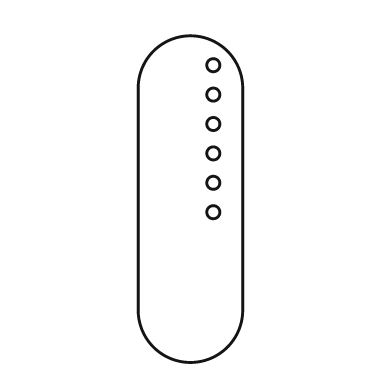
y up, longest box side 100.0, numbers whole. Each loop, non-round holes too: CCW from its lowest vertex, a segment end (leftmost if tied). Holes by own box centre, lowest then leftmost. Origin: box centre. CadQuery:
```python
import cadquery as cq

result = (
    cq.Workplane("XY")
    .moveTo(-16.0, -34.0)
    .threePointArc((0.0, -50.0), (16.0, -34.0))
    .lineTo(16.0, 34.0)
    .threePointArc((0.0, 50.0), (-16.0, 34.0))
    .close()
    .moveTo(7.0, -4.0)
    .circle(2.0)
    .moveTo(7.0, 5.0)
    .circle(2.0)
    .moveTo(7.0, 14.0)
    .circle(2.0)
    .moveTo(7.0, 23.0)
    .circle(2.0)
    .moveTo(7.0, 32.0)
    .circle(2.0)
    .moveTo(7.0, 41.0)
    .circle(2.0)
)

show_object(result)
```